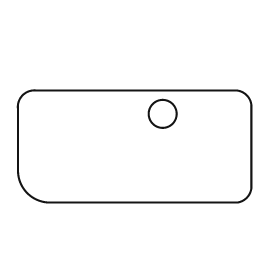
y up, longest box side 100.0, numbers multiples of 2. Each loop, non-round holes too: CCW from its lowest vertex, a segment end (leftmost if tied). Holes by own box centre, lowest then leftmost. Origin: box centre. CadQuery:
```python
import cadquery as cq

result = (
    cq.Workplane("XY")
    .moveTo(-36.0, -24.0)
    .lineTo(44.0, -24.0)
    .threePointArc((48.0, -22.0), (50.0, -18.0))
    .lineTo(50.0, 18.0)
    .threePointArc((48.0, 22.0), (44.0, 24.0))
    .lineTo(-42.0, 24.0)
    .threePointArc((-48.0, 22.0), (-50.0, 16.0))
    .lineTo(-50.0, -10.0)
    .threePointArc((-46.0, -20.0), (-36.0, -24.0))
    .close()
    .moveTo(12.0, 14.0)
    .circle(6.0)
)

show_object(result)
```